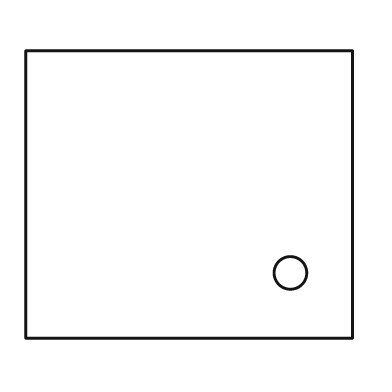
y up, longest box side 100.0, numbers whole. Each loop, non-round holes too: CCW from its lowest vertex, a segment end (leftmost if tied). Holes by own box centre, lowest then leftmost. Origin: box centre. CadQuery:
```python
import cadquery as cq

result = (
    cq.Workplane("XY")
    .moveTo(-50.0, -44.0)
    .lineTo(50.0, -44.0)
    .lineTo(50.0, 44.0)
    .lineTo(-50.0, 44.0)
    .close()
    .moveTo(31.0, -24.0)
    .circle(5.0)
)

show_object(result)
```